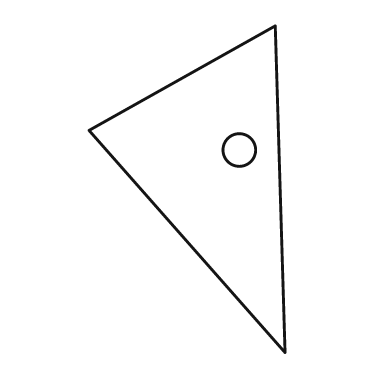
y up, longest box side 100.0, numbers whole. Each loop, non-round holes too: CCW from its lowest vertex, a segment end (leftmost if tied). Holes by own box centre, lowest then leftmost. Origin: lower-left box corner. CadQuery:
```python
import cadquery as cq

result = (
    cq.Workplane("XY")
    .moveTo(60.0, 0.0)
    .lineTo(57.0, 100.0)
    .lineTo(0.0, 68.0)
    .close()
    .moveTo(46.0, 62.0)
    .circle(5.0)
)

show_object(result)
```